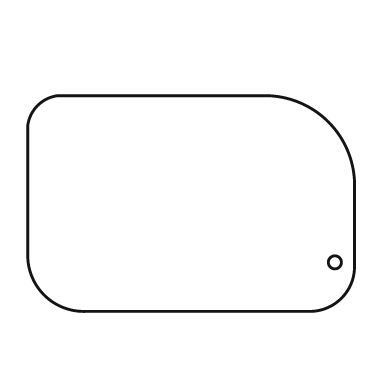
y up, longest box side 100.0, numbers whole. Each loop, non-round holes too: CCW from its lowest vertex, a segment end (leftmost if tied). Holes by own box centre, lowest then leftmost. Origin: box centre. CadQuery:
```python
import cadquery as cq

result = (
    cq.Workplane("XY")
    .moveTo(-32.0, -33.0)
    .lineTo(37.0, -33.0)
    .threePointArc((46.0, -29.0), (50.0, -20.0))
    .lineTo(50.0, 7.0)
    .threePointArc((42.0, 25.0), (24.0, 33.0))
    .lineTo(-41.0, 33.0)
    .threePointArc((-47.0, 30.0), (-50.0, 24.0))
    .lineTo(-50.0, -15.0)
    .threePointArc((-45.0, -28.0), (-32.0, -33.0))
    .close()
    .moveTo(44.0, -18.0)
    .circle(2.0)
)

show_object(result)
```